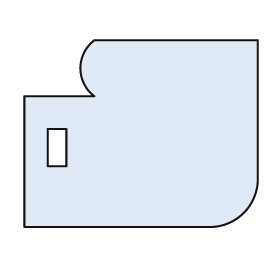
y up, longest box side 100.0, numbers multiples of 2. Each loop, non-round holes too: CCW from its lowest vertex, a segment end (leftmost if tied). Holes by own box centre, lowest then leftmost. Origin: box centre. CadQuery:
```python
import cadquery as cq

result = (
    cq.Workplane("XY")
    .moveTo(-50.0, -40.0)
    .lineTo(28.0, -40.0)
    .threePointArc((44.0, -34.0), (50.0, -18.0))
    .lineTo(50.0, 40.0)
    .lineTo(-20.0, 40.0)
    .threePointArc((-26.0, 28.0), (-20.0, 16.0))
    .lineTo(-50.0, 16.0)
    .close()
    .moveTo(-40.0, -14.0)
    .lineTo(-32.0, -14.0)
    .lineTo(-32.0, 2.0)
    .lineTo(-40.0, 2.0)
    .close()
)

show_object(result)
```